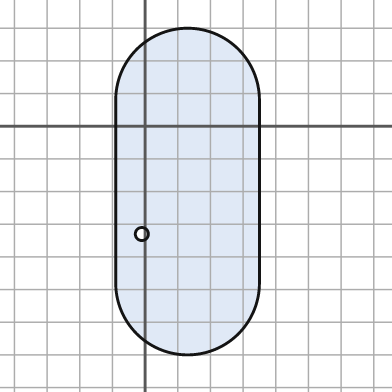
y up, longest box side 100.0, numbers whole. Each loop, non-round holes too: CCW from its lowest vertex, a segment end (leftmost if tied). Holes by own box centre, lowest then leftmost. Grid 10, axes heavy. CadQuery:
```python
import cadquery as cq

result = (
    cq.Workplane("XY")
    .moveTo(-9.0, -48.0)
    .threePointArc((13.0, -70.0), (35.0, -48.0))
    .lineTo(35.0, 8.0)
    .threePointArc((13.0, 30.0), (-9.0, 8.0))
    .close()
    .moveTo(-1.0, -33.0)
    .circle(2.0)
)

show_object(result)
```